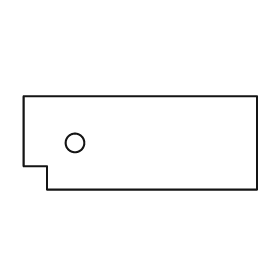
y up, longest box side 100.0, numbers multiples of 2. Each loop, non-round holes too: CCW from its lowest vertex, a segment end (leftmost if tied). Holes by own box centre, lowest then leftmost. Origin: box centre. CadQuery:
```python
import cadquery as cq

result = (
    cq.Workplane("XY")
    .moveTo(-40.0, -20.0)
    .lineTo(50.0, -20.0)
    .lineTo(50.0, 20.0)
    .lineTo(-50.0, 20.0)
    .lineTo(-50.0, -10.0)
    .lineTo(-40.0, -10.0)
    .close()
    .moveTo(-28.0, 0.0)
    .circle(4.0)
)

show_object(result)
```